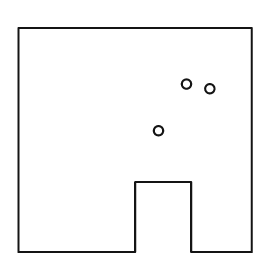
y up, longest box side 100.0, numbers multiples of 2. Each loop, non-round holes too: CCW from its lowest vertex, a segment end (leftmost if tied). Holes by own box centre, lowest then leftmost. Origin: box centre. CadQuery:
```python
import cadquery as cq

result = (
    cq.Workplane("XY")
    .moveTo(-50.0, -48.0)
    .lineTo(0.0, -48.0)
    .lineTo(0.0, -18.0)
    .lineTo(24.0, -18.0)
    .lineTo(24.0, -48.0)
    .lineTo(50.0, -48.0)
    .lineTo(50.0, 48.0)
    .lineTo(-50.0, 48.0)
    .close()
    .moveTo(10.0, 4.0)
    .circle(2.0)
    .moveTo(32.0, 22.0)
    .circle(2.0)
    .moveTo(22.0, 24.0)
    .circle(2.0)
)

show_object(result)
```